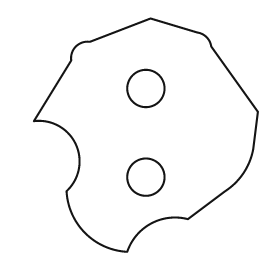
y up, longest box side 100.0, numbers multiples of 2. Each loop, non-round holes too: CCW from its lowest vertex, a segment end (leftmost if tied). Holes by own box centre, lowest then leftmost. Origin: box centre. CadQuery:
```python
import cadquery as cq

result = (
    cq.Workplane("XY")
    .moveTo(-8.0, -50.0)
    .threePointArc((2.0, -38.0), (18.0, -36.0))
    .lineTo(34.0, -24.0)
    .threePointArc((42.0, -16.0), (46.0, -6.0))
    .lineTo(48.0, 10.0)
    .lineTo(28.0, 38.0)
    .threePointArc((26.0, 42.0), (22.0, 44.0))
    .lineTo(2.0, 50.0)
    .lineTo(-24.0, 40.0)
    .threePointArc((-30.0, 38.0), (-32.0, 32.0))
    .lineTo(-48.0, 6.0)
    .threePointArc((-30.0, -4.0), (-34.0, -24.0))
    .threePointArc((-26.0, -42.0), (-8.0, -50.0))
    .close()
    .moveTo(0.0, -18.0)
    .circle(8.0)
    .moveTo(0.0, 20.0)
    .circle(8.0)
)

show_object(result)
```